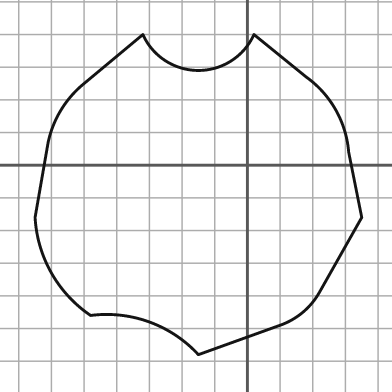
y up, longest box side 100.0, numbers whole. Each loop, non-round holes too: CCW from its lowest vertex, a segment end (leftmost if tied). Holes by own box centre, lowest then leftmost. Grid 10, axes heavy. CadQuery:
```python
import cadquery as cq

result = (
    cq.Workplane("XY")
    .moveTo(-15.0, -58.0)
    .lineTo(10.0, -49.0)
    .threePointArc((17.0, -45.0), (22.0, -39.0))
    .lineTo(35.0, -16.0)
    .lineTo(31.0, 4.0)
    .threePointArc((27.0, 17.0), (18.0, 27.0))
    .lineTo(2.0, 40.0)
    .threePointArc((-15.0, 29.0), (-32.0, 40.0))
    .lineTo(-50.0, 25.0)
    .threePointArc((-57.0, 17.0), (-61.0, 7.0))
    .lineTo(-65.0, -16.0)
    .threePointArc((-60.0, -33.0), (-48.0, -46.0))
    .threePointArc((-30.0, -48.0), (-15.0, -58.0))
    .close()
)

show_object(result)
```